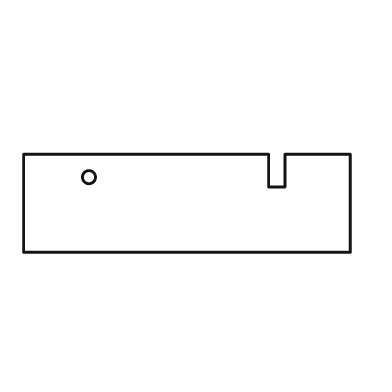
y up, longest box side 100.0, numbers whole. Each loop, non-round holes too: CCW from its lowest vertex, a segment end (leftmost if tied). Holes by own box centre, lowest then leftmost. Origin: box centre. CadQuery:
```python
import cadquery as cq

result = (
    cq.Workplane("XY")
    .moveTo(-50.0, -15.0)
    .lineTo(50.0, -15.0)
    .lineTo(50.0, 15.0)
    .lineTo(30.0, 15.0)
    .lineTo(30.0, 5.0)
    .lineTo(25.0, 5.0)
    .lineTo(25.0, 15.0)
    .lineTo(-50.0, 15.0)
    .close()
    .moveTo(-30.0, 8.0)
    .circle(2.0)
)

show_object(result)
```